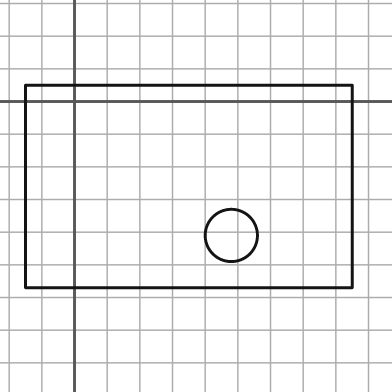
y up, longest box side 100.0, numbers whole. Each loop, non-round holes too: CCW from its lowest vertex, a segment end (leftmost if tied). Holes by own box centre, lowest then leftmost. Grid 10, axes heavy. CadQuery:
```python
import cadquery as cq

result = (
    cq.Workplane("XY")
    .moveTo(-15.0, -57.0)
    .lineTo(85.0, -57.0)
    .lineTo(85.0, 5.0)
    .lineTo(-15.0, 5.0)
    .close()
    .moveTo(48.0, -41.0)
    .circle(8.0)
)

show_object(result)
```